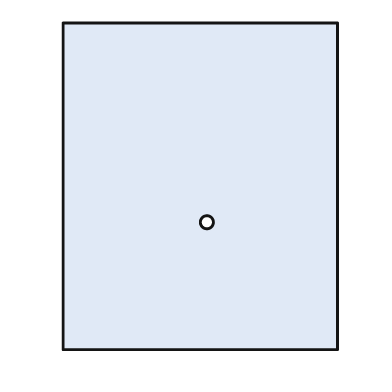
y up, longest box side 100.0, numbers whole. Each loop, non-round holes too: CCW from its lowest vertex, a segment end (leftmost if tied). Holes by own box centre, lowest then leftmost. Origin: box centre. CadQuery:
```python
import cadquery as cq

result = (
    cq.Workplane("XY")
    .moveTo(-42.0, -50.0)
    .lineTo(42.0, -50.0)
    .lineTo(42.0, 50.0)
    .lineTo(-42.0, 50.0)
    .close()
    .moveTo(2.0, -11.0)
    .circle(2.0)
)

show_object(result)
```